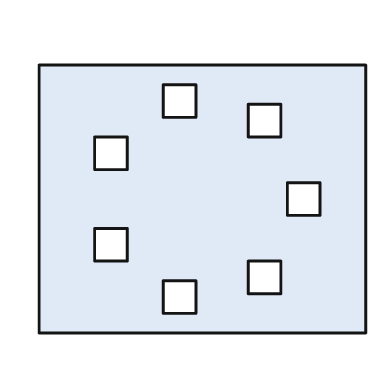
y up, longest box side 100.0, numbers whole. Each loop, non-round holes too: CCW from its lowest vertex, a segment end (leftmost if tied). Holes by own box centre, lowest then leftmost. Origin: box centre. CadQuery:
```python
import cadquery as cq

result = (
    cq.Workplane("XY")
    .moveTo(-50.0, -41.0)
    .lineTo(50.0, -41.0)
    .lineTo(50.0, 41.0)
    .lineTo(-50.0, 41.0)
    .close()
    .moveTo(-12.0, -35.0)
    .lineTo(-2.0, -35.0)
    .lineTo(-2.0, -25.0)
    .lineTo(-12.0, -25.0)
    .close()
    .moveTo(14.0, -29.0)
    .lineTo(24.0, -29.0)
    .lineTo(24.0, -19.0)
    .lineTo(14.0, -19.0)
    .close()
    .moveTo(-33.0, -19.0)
    .lineTo(-23.0, -19.0)
    .lineTo(-23.0, -9.0)
    .lineTo(-33.0, -9.0)
    .close()
    .moveTo(26.0, -5.0)
    .lineTo(36.0, -5.0)
    .lineTo(36.0, 5.0)
    .lineTo(26.0, 5.0)
    .close()
    .moveTo(-33.0, 9.0)
    .lineTo(-23.0, 9.0)
    .lineTo(-23.0, 19.0)
    .lineTo(-33.0, 19.0)
    .close()
    .moveTo(14.0, 19.0)
    .lineTo(24.0, 19.0)
    .lineTo(24.0, 29.0)
    .lineTo(14.0, 29.0)
    .close()
    .moveTo(-12.0, 25.0)
    .lineTo(-2.0, 25.0)
    .lineTo(-2.0, 35.0)
    .lineTo(-12.0, 35.0)
    .close()
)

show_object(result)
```